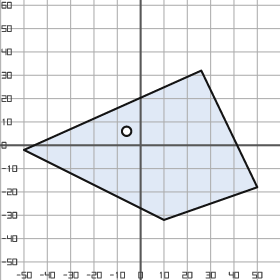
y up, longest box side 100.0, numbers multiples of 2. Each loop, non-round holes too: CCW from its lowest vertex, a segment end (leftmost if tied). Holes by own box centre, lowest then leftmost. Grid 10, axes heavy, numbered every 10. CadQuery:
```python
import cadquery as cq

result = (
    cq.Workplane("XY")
    .moveTo(10.0, -32.0)
    .lineTo(50.0, -18.0)
    .lineTo(26.0, 32.0)
    .lineTo(-50.0, -2.0)
    .close()
    .moveTo(-6.0, 6.0)
    .circle(2.0)
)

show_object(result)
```